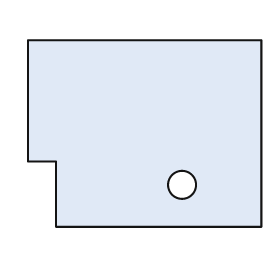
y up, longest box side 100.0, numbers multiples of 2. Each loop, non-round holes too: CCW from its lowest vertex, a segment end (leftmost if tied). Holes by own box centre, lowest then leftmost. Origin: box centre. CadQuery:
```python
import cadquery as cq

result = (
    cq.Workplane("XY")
    .moveTo(-38.0, -40.0)
    .lineTo(50.0, -40.0)
    .lineTo(50.0, 40.0)
    .lineTo(-50.0, 40.0)
    .lineTo(-50.0, -12.0)
    .lineTo(-38.0, -12.0)
    .close()
    .moveTo(16.0, -22.0)
    .circle(6.0)
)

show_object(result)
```